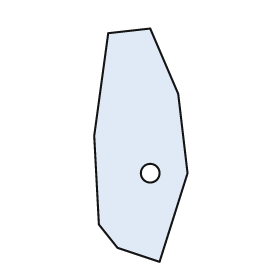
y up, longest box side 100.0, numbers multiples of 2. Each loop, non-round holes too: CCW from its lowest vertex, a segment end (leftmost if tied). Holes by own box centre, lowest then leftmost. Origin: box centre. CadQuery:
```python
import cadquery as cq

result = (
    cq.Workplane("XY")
    .moveTo(8.0, -50.0)
    .lineTo(20.0, -12.0)
    .lineTo(16.0, 22.0)
    .lineTo(4.0, 50.0)
    .lineTo(-14.0, 48.0)
    .lineTo(-20.0, 4.0)
    .lineTo(-18.0, -34.0)
    .lineTo(-10.0, -44.0)
    .close()
    .moveTo(4.0, -12.0)
    .circle(4.0)
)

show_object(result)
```